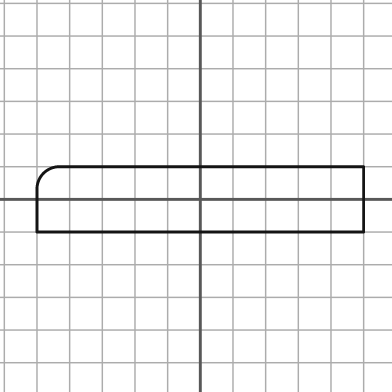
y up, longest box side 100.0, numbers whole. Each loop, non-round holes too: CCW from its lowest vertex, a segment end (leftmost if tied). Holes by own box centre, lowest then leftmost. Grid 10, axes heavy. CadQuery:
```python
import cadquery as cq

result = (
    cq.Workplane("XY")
    .moveTo(-50.0, -10.0)
    .lineTo(50.0, -10.0)
    .lineTo(50.0, 10.0)
    .lineTo(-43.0, 10.0)
    .threePointArc((-48.0, 8.0), (-50.0, 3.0))
    .close()
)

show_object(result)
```